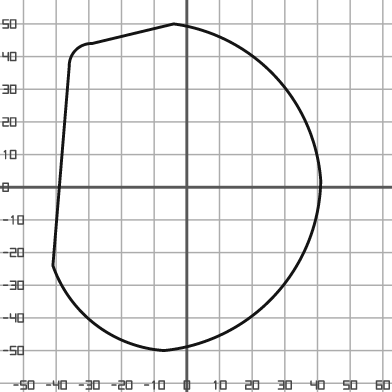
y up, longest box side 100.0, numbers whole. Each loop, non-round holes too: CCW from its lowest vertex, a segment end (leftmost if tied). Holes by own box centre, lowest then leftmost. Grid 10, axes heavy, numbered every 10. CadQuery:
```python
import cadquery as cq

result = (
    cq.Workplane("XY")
    .moveTo(-7.0, -50.0)
    .threePointArc((27.0, -33.0), (41.0, 2.0))
    .threePointArc((27.0, 34.0), (-4.0, 50.0))
    .lineTo(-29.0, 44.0)
    .threePointArc((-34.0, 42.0), (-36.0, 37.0))
    .lineTo(-41.0, -24.0)
    .threePointArc((-28.0, -42.0), (-7.0, -50.0))
    .close()
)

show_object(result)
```